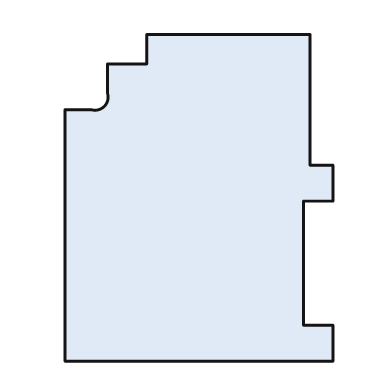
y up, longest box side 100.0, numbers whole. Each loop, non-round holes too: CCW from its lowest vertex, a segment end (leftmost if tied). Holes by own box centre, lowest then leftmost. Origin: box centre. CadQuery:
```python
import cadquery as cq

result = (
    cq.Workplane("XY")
    .moveTo(-41.0, -50.0)
    .lineTo(41.0, -50.0)
    .lineTo(41.0, -39.0)
    .lineTo(32.0, -39.0)
    .lineTo(32.0, -1.0)
    .lineTo(41.0, -1.0)
    .lineTo(41.0, 10.0)
    .lineTo(34.0, 10.0)
    .lineTo(34.0, 50.0)
    .lineTo(-16.0, 50.0)
    .lineTo(-16.0, 41.0)
    .lineTo(-28.0, 41.0)
    .lineTo(-28.0, 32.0)
    .threePointArc((-29.0, 28.0), (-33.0, 27.0))
    .lineTo(-41.0, 27.0)
    .close()
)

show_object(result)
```